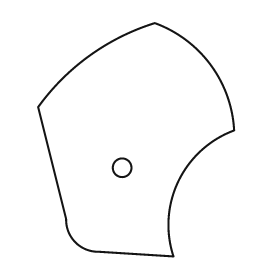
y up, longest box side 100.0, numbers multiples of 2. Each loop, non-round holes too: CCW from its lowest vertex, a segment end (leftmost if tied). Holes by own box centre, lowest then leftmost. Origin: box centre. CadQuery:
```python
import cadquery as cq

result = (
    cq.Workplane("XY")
    .moveTo(16.0, -50.0)
    .threePointArc((18.0, -18.0), (42.0, 4.0))
    .threePointArc((32.0, 32.0), (8.0, 50.0))
    .threePointArc((-20.0, 36.0), (-42.0, 14.0))
    .lineTo(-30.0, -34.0)
    .threePointArc((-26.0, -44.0), (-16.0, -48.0))
    .close()
    .moveTo(-6.0, -12.0)
    .circle(4.0)
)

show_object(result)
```